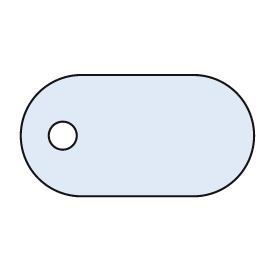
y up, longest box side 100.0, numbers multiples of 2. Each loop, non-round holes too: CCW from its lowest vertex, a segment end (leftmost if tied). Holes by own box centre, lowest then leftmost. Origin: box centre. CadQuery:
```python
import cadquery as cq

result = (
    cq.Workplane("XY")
    .moveTo(-24.0, -26.0)
    .lineTo(24.0, -26.0)
    .threePointArc((50.0, 0.0), (24.0, 26.0))
    .lineTo(-24.0, 26.0)
    .threePointArc((-50.0, 0.0), (-24.0, -26.0))
    .close()
    .moveTo(-32.0, 0.0)
    .circle(6.0)
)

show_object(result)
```